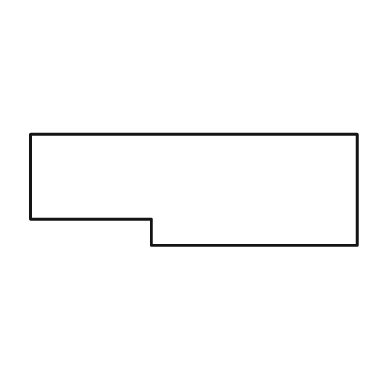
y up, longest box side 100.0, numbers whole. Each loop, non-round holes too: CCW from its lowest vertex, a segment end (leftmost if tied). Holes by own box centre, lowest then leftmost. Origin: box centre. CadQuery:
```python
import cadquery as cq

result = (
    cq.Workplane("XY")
    .moveTo(-13.0, -17.0)
    .lineTo(50.0, -17.0)
    .lineTo(50.0, 17.0)
    .lineTo(-50.0, 17.0)
    .lineTo(-50.0, -9.0)
    .lineTo(-13.0, -9.0)
    .close()
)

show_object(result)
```